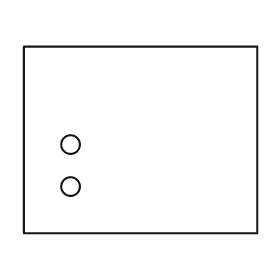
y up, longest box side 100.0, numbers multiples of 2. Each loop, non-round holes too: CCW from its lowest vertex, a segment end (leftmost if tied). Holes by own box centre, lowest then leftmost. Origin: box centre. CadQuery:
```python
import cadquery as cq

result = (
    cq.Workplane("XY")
    .moveTo(-50.0, -40.0)
    .lineTo(50.0, -40.0)
    .lineTo(50.0, 40.0)
    .lineTo(-50.0, 40.0)
    .close()
    .moveTo(-30.0, -20.0)
    .circle(4.0)
    .moveTo(-30.0, -2.0)
    .circle(4.0)
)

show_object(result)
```